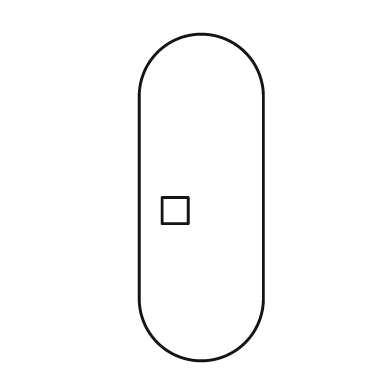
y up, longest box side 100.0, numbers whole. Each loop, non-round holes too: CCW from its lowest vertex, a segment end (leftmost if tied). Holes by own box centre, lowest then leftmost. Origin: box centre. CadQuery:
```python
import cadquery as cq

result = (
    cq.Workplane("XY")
    .moveTo(-19.0, -31.0)
    .threePointArc((0.0, -50.0), (19.0, -31.0))
    .lineTo(19.0, 31.0)
    .threePointArc((0.0, 50.0), (-19.0, 31.0))
    .close()
    .moveTo(-12.0, -8.0)
    .lineTo(-4.0, -8.0)
    .lineTo(-4.0, 0.0)
    .lineTo(-12.0, 0.0)
    .close()
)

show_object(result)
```